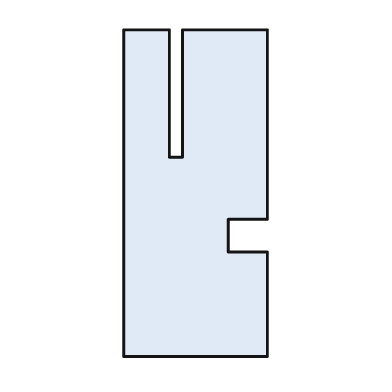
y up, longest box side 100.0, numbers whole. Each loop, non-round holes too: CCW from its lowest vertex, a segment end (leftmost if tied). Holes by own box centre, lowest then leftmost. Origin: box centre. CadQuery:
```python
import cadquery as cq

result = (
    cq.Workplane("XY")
    .moveTo(-22.0, -50.0)
    .lineTo(22.0, -50.0)
    .lineTo(22.0, -18.0)
    .lineTo(10.0, -18.0)
    .lineTo(10.0, -8.0)
    .lineTo(22.0, -8.0)
    .lineTo(22.0, 50.0)
    .lineTo(-4.0, 50.0)
    .lineTo(-4.0, 11.0)
    .lineTo(-8.0, 11.0)
    .lineTo(-8.0, 50.0)
    .lineTo(-22.0, 50.0)
    .close()
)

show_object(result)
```